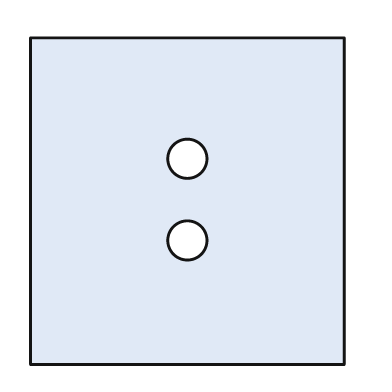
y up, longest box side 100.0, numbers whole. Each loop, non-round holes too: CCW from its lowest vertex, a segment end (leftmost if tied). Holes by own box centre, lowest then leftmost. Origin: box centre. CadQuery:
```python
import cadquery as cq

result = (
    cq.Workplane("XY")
    .moveTo(-48.0, -50.0)
    .lineTo(48.0, -50.0)
    .lineTo(48.0, 50.0)
    .lineTo(-48.0, 50.0)
    .close()
    .moveTo(0.0, -12.0)
    .circle(6.0)
    .moveTo(0.0, 13.0)
    .circle(6.0)
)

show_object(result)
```